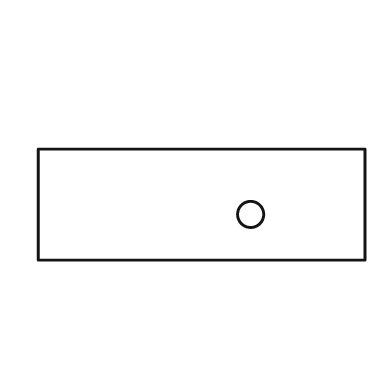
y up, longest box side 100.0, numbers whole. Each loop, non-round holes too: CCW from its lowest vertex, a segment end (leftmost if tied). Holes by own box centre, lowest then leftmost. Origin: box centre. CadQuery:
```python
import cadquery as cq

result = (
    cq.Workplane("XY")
    .moveTo(-50.0, -17.0)
    .lineTo(50.0, -17.0)
    .lineTo(50.0, 17.0)
    .lineTo(-50.0, 17.0)
    .close()
    .moveTo(15.0, -3.0)
    .circle(4.0)
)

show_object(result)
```